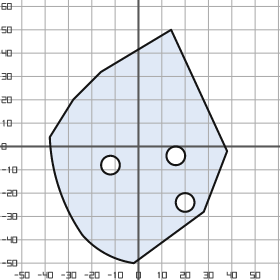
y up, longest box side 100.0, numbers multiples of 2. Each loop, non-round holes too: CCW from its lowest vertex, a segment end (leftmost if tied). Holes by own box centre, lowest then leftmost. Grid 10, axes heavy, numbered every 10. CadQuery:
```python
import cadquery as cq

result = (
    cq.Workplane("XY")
    .moveTo(-2.0, -50.0)
    .lineTo(28.0, -28.0)
    .lineTo(38.0, -2.0)
    .lineTo(14.0, 50.0)
    .lineTo(-16.0, 32.0)
    .lineTo(-28.0, 20.0)
    .lineTo(-38.0, 4.0)
    .threePointArc((-34.0, -18.0), (-24.0, -38.0))
    .threePointArc((-14.0, -46.0), (-2.0, -50.0))
    .close()
    .moveTo(20.0, -24.0)
    .circle(4.0)
    .moveTo(-12.0, -8.0)
    .circle(4.0)
    .moveTo(16.0, -4.0)
    .circle(4.0)
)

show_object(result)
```